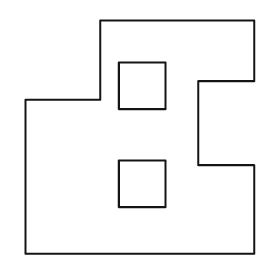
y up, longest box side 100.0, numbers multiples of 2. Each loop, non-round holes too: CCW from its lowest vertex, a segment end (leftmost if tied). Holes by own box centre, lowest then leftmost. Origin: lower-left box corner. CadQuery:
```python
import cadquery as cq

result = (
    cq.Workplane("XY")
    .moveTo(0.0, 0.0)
    .lineTo(98.0, 0.0)
    .lineTo(98.0, 38.0)
    .lineTo(74.0, 38.0)
    .lineTo(74.0, 74.0)
    .lineTo(98.0, 74.0)
    .lineTo(98.0, 100.0)
    .lineTo(32.0, 100.0)
    .lineTo(32.0, 66.0)
    .lineTo(0.0, 66.0)
    .close()
    .moveTo(40.0, 20.0)
    .lineTo(60.0, 20.0)
    .lineTo(60.0, 40.0)
    .lineTo(40.0, 40.0)
    .close()
    .moveTo(40.0, 62.0)
    .lineTo(60.0, 62.0)
    .lineTo(60.0, 82.0)
    .lineTo(40.0, 82.0)
    .close()
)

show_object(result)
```